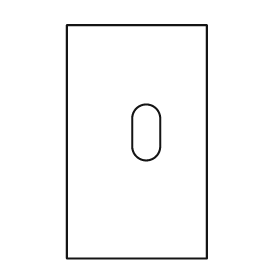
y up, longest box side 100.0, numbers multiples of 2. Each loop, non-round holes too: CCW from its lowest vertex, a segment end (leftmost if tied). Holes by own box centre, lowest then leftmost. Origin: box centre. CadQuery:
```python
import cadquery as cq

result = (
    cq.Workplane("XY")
    .moveTo(-30.0, -50.0)
    .lineTo(30.0, -50.0)
    .lineTo(30.0, 50.0)
    .lineTo(-30.0, 50.0)
    .close()
    .moveTo(-2.0, -2.0)
    .threePointArc((4.0, -8.0), (10.0, -2.0))
    .lineTo(10.0, 10.0)
    .threePointArc((4.0, 16.0), (-2.0, 10.0))
    .close()
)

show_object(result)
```